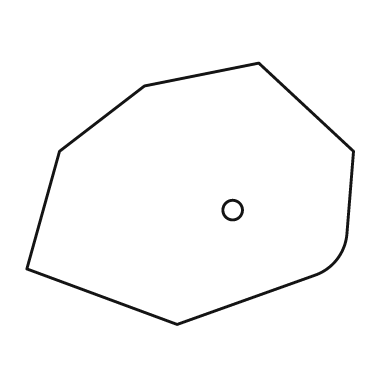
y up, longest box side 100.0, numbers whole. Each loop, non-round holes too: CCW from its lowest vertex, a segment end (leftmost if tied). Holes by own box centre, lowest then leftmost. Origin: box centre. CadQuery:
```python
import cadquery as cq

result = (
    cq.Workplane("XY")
    .moveTo(-4.0, -40.0)
    .lineTo(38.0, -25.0)
    .threePointArc((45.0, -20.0), (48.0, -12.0))
    .lineTo(50.0, 13.0)
    .lineTo(21.0, 40.0)
    .lineTo(-14.0, 33.0)
    .lineTo(-40.0, 13.0)
    .lineTo(-50.0, -23.0)
    .close()
    .moveTo(13.0, -5.0)
    .circle(3.0)
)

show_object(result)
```